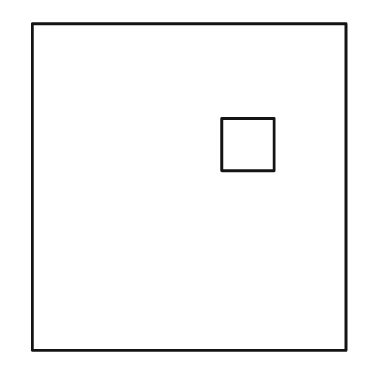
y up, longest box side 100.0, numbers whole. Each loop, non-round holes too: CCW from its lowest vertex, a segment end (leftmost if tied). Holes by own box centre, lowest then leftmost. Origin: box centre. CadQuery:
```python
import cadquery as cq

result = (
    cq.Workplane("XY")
    .moveTo(-48.0, -50.0)
    .lineTo(48.0, -50.0)
    .lineTo(48.0, 50.0)
    .lineTo(-48.0, 50.0)
    .close()
    .moveTo(10.0, 5.0)
    .lineTo(26.0, 5.0)
    .lineTo(26.0, 21.0)
    .lineTo(10.0, 21.0)
    .close()
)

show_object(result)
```